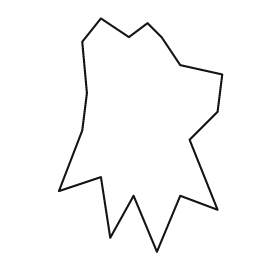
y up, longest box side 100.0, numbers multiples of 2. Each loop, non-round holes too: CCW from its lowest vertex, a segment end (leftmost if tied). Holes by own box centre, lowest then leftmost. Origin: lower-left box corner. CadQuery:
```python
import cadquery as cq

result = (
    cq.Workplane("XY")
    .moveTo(42.0, 0.0)
    .lineTo(52.0, 24.0)
    .lineTo(68.0, 18.0)
    .lineTo(56.0, 48.0)
    .lineTo(68.0, 60.0)
    .lineTo(70.0, 76.0)
    .lineTo(52.0, 80.0)
    .lineTo(44.0, 92.0)
    .lineTo(38.0, 98.0)
    .lineTo(30.0, 92.0)
    .lineTo(18.0, 100.0)
    .lineTo(10.0, 90.0)
    .lineTo(12.0, 68.0)
    .lineTo(10.0, 52.0)
    .lineTo(0.0, 26.0)
    .lineTo(18.0, 32.0)
    .lineTo(22.0, 6.0)
    .lineTo(32.0, 24.0)
    .close()
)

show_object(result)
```